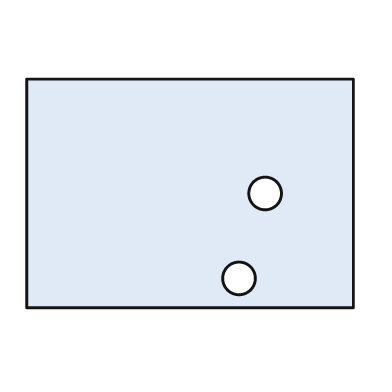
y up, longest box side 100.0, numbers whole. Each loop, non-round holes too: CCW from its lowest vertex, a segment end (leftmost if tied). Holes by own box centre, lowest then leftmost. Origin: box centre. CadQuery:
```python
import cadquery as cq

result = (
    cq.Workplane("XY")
    .moveTo(-50.0, -35.0)
    .lineTo(50.0, -35.0)
    .lineTo(50.0, 35.0)
    .lineTo(-50.0, 35.0)
    .close()
    .moveTo(15.0, -26.0)
    .circle(5.0)
    .moveTo(23.0, 0.0)
    .circle(5.0)
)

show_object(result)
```